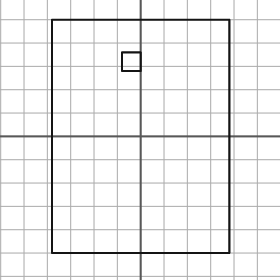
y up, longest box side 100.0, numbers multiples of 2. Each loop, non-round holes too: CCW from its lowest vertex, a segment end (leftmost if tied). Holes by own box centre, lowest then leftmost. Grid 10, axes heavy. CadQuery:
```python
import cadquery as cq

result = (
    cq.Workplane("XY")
    .moveTo(-38.0, -50.0)
    .lineTo(38.0, -50.0)
    .lineTo(38.0, 50.0)
    .lineTo(-38.0, 50.0)
    .close()
    .moveTo(-8.0, 28.0)
    .lineTo(0.0, 28.0)
    .lineTo(0.0, 36.0)
    .lineTo(-8.0, 36.0)
    .close()
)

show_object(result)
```